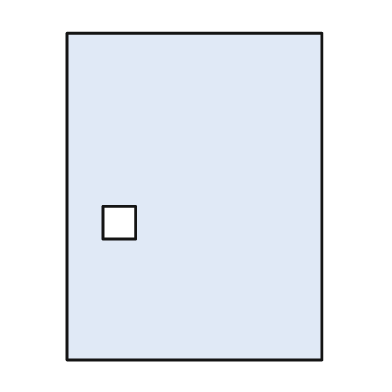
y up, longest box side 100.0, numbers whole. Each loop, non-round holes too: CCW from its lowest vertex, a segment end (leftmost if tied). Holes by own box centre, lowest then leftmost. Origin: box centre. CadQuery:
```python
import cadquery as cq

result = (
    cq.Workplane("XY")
    .moveTo(-39.0, -50.0)
    .lineTo(39.0, -50.0)
    .lineTo(39.0, 50.0)
    .lineTo(-39.0, 50.0)
    .close()
    .moveTo(-28.0, -13.0)
    .lineTo(-18.0, -13.0)
    .lineTo(-18.0, -3.0)
    .lineTo(-28.0, -3.0)
    .close()
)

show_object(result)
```